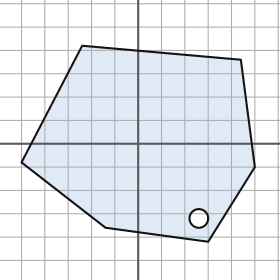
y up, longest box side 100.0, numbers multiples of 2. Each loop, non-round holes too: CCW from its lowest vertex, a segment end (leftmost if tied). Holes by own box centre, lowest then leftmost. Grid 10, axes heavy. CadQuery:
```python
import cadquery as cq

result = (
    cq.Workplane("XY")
    .moveTo(30.0, -42.0)
    .lineTo(50.0, -10.0)
    .lineTo(44.0, 36.0)
    .lineTo(-24.0, 42.0)
    .lineTo(-50.0, -8.0)
    .lineTo(-14.0, -36.0)
    .close()
    .moveTo(26.0, -32.0)
    .circle(4.0)
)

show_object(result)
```